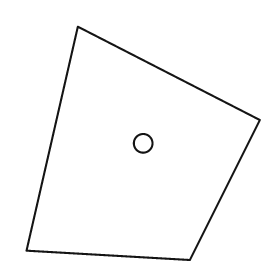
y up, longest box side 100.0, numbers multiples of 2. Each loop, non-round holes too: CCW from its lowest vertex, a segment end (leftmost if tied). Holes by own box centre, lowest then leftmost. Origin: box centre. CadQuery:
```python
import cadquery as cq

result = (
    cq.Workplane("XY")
    .moveTo(20.0, -50.0)
    .lineTo(50.0, 10.0)
    .lineTo(-28.0, 50.0)
    .lineTo(-50.0, -46.0)
    .close()
    .moveTo(0.0, 0.0)
    .circle(4.0)
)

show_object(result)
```